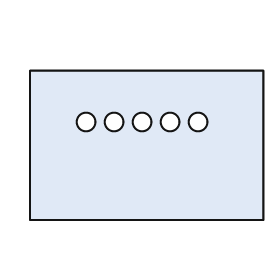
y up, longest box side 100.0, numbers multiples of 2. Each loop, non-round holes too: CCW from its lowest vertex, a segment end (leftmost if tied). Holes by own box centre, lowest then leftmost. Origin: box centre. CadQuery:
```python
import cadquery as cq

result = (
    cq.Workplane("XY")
    .moveTo(-50.0, -32.0)
    .lineTo(50.0, -32.0)
    .lineTo(50.0, 32.0)
    .lineTo(-50.0, 32.0)
    .close()
    .moveTo(-26.0, 10.0)
    .circle(4.0)
    .moveTo(-14.0, 10.0)
    .circle(4.0)
    .moveTo(-2.0, 10.0)
    .circle(4.0)
    .moveTo(10.0, 10.0)
    .circle(4.0)
    .moveTo(22.0, 10.0)
    .circle(4.0)
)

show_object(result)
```